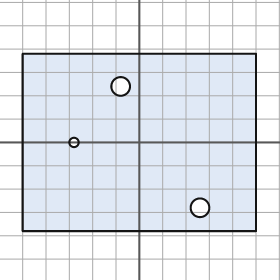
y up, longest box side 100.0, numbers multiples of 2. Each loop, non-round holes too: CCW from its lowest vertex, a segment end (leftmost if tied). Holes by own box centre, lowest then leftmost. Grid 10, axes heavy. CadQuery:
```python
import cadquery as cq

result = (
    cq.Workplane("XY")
    .moveTo(-50.0, -38.0)
    .lineTo(50.0, -38.0)
    .lineTo(50.0, 38.0)
    .lineTo(-50.0, 38.0)
    .close()
    .moveTo(26.0, -28.0)
    .circle(4.0)
    .moveTo(-28.0, 0.0)
    .circle(2.0)
    .moveTo(-8.0, 24.0)
    .circle(4.0)
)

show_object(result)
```